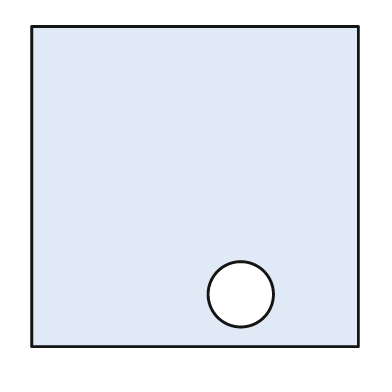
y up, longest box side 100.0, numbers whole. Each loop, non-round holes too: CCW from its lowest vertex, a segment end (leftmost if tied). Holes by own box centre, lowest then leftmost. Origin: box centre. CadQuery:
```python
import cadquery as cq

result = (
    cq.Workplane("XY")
    .moveTo(-50.0, -49.0)
    .lineTo(50.0, -49.0)
    .lineTo(50.0, 49.0)
    .lineTo(-50.0, 49.0)
    .close()
    .moveTo(14.0, -33.0)
    .circle(10.0)
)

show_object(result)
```